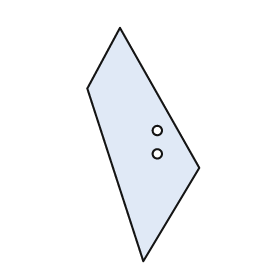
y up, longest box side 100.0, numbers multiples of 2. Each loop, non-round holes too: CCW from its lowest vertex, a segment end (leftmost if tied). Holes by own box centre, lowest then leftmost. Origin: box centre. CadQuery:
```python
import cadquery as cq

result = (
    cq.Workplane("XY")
    .moveTo(0.0, -50.0)
    .lineTo(24.0, -10.0)
    .lineTo(-10.0, 50.0)
    .lineTo(-24.0, 24.0)
    .close()
    .moveTo(6.0, -4.0)
    .circle(2.0)
    .moveTo(6.0, 6.0)
    .circle(2.0)
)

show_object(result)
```